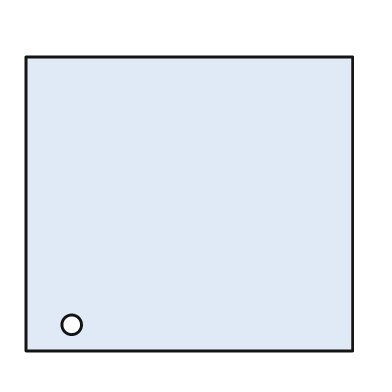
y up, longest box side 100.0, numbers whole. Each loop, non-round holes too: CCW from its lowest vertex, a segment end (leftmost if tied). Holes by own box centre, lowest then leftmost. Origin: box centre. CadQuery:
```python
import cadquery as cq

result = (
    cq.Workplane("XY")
    .moveTo(-50.0, -45.0)
    .lineTo(50.0, -45.0)
    .lineTo(50.0, 45.0)
    .lineTo(-50.0, 45.0)
    .close()
    .moveTo(-36.0, -37.0)
    .circle(3.0)
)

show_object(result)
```